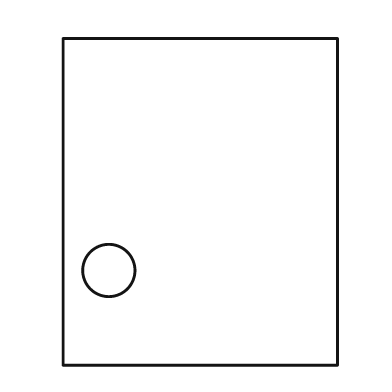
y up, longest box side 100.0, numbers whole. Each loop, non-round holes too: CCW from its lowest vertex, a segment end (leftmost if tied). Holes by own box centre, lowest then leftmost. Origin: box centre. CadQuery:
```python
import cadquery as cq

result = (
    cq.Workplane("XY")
    .moveTo(-42.0, -50.0)
    .lineTo(42.0, -50.0)
    .lineTo(42.0, 50.0)
    .lineTo(-42.0, 50.0)
    .close()
    .moveTo(-28.0, -21.0)
    .circle(8.0)
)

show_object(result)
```